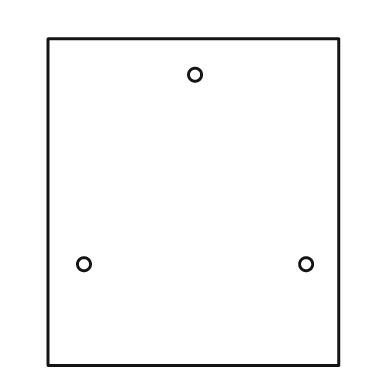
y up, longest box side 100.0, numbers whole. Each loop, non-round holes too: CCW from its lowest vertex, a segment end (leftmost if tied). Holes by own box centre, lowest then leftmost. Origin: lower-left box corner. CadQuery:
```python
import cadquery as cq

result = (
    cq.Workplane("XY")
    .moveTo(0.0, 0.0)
    .lineTo(89.0, 0.0)
    .lineTo(89.0, 100.0)
    .lineTo(0.0, 100.0)
    .close()
    .moveTo(11.0, 31.0)
    .circle(2.0)
    .moveTo(79.0, 31.0)
    .circle(2.0)
    .moveTo(45.0, 89.0)
    .circle(2.0)
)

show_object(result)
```